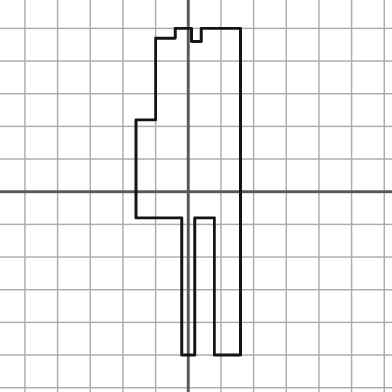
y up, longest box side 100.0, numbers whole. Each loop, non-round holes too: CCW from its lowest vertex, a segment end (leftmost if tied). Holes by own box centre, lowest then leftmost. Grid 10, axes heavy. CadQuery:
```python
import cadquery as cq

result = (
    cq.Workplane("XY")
    .moveTo(-2.0, -50.0)
    .lineTo(2.0, -50.0)
    .lineTo(2.0, -8.0)
    .lineTo(8.0, -8.0)
    .lineTo(8.0, -50.0)
    .lineTo(16.0, -50.0)
    .lineTo(16.0, 50.0)
    .lineTo(4.0, 50.0)
    .lineTo(4.0, 46.0)
    .lineTo(1.0, 46.0)
    .lineTo(1.0, 50.0)
    .lineTo(-4.0, 50.0)
    .lineTo(-4.0, 47.0)
    .lineTo(-10.0, 47.0)
    .lineTo(-10.0, 22.0)
    .lineTo(-16.0, 22.0)
    .lineTo(-16.0, -8.0)
    .lineTo(-2.0, -8.0)
    .close()
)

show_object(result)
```